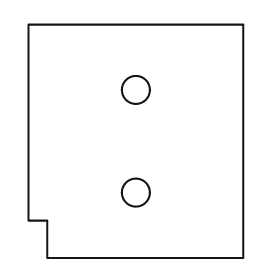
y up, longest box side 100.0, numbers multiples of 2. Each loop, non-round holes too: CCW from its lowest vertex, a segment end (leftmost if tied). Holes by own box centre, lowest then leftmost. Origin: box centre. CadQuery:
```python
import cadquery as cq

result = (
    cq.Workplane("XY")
    .moveTo(-38.0, -50.0)
    .lineTo(46.0, -50.0)
    .lineTo(46.0, 50.0)
    .lineTo(-46.0, 50.0)
    .lineTo(-46.0, -34.0)
    .lineTo(-38.0, -34.0)
    .close()
    .moveTo(0.0, -22.0)
    .circle(6.0)
    .moveTo(0.0, 22.0)
    .circle(6.0)
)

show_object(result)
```